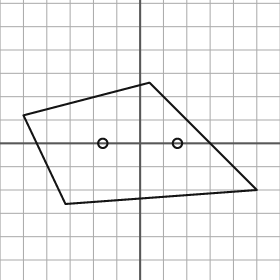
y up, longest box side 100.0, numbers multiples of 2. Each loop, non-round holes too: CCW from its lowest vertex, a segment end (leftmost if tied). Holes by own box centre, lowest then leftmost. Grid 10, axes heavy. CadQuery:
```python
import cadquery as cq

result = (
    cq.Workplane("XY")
    .moveTo(-32.0, -26.0)
    .lineTo(50.0, -20.0)
    .lineTo(4.0, 26.0)
    .lineTo(-50.0, 12.0)
    .close()
    .moveTo(-16.0, 0.0)
    .circle(2.0)
    .moveTo(16.0, 0.0)
    .circle(2.0)
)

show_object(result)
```